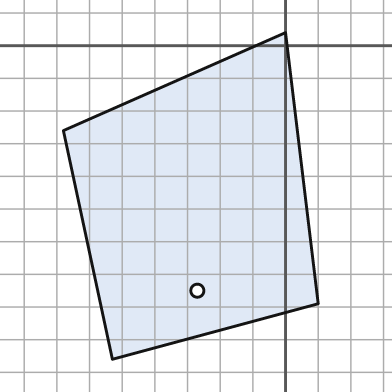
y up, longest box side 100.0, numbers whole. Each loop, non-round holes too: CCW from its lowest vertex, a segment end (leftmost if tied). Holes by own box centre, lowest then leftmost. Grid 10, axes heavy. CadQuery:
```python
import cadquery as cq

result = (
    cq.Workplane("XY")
    .moveTo(-53.0, -96.0)
    .lineTo(10.0, -79.0)
    .lineTo(0.0, 4.0)
    .lineTo(-68.0, -26.0)
    .close()
    .moveTo(-27.0, -75.0)
    .circle(2.0)
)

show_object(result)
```